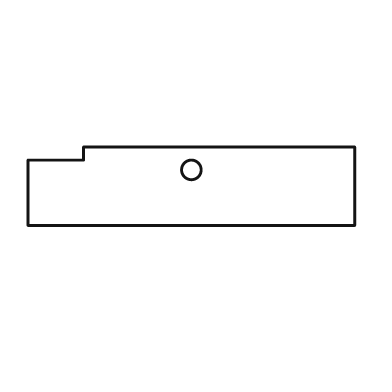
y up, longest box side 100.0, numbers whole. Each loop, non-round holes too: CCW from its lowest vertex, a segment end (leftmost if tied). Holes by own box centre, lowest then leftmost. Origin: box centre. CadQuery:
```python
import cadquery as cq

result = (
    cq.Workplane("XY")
    .moveTo(-50.0, -12.0)
    .lineTo(50.0, -12.0)
    .lineTo(50.0, 12.0)
    .lineTo(-33.0, 12.0)
    .lineTo(-33.0, 8.0)
    .lineTo(-50.0, 8.0)
    .close()
    .moveTo(0.0, 5.0)
    .circle(3.0)
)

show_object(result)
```